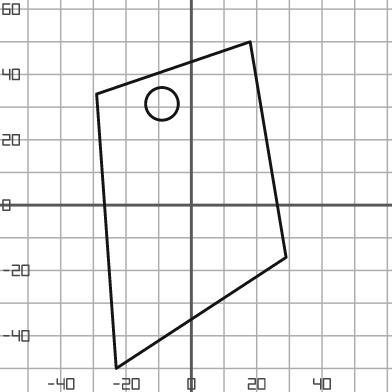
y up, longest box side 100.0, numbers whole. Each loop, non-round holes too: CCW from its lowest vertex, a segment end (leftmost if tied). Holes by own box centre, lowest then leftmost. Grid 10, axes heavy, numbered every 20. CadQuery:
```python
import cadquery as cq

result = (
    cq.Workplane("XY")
    .moveTo(-23.0, -50.0)
    .lineTo(29.0, -16.0)
    .lineTo(18.0, 50.0)
    .lineTo(-29.0, 34.0)
    .close()
    .moveTo(-9.0, 31.0)
    .circle(5.0)
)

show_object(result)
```